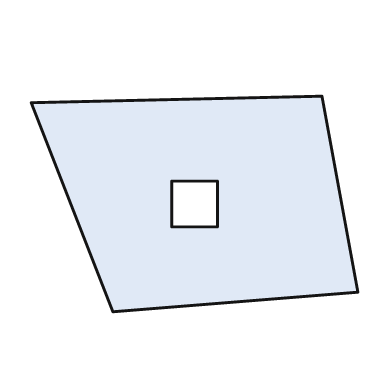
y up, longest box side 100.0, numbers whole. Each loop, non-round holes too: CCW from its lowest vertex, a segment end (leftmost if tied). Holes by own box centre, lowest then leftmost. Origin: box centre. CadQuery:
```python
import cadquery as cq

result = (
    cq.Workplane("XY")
    .moveTo(-25.0, -33.0)
    .lineTo(50.0, -27.0)
    .lineTo(39.0, 33.0)
    .lineTo(-50.0, 31.0)
    .close()
    .moveTo(-7.0, -7.0)
    .lineTo(7.0, -7.0)
    .lineTo(7.0, 7.0)
    .lineTo(-7.0, 7.0)
    .close()
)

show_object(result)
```